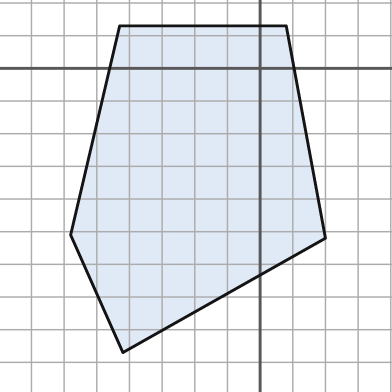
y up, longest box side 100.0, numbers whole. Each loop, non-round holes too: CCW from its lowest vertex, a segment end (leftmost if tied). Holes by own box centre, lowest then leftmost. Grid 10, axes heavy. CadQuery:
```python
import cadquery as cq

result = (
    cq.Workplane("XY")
    .moveTo(-42.0, -87.0)
    .lineTo(20.0, -52.0)
    .lineTo(8.0, 13.0)
    .lineTo(-43.0, 13.0)
    .lineTo(-58.0, -51.0)
    .close()
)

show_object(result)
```